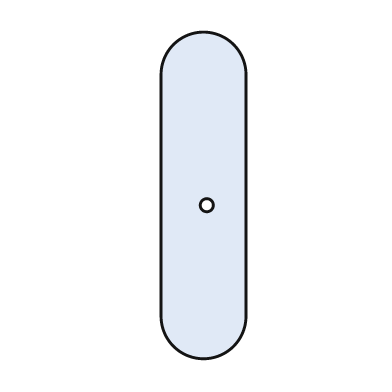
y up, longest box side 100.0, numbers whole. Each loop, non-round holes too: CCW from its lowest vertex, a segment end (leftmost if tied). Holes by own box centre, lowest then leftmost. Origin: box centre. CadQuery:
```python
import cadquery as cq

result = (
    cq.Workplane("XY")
    .moveTo(-13.0, -37.0)
    .threePointArc((0.0, -50.0), (13.0, -37.0))
    .lineTo(13.0, 37.0)
    .threePointArc((0.0, 50.0), (-13.0, 37.0))
    .close()
    .moveTo(1.0, -3.0)
    .circle(2.0)
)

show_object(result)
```